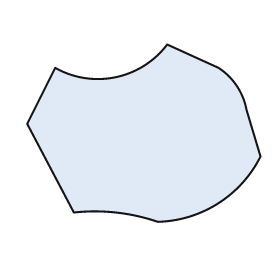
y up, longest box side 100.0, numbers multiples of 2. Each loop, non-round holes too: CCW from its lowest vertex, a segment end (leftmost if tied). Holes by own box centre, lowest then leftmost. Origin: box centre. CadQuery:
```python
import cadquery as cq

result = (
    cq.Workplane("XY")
    .moveTo(6.0, -38.0)
    .threePointArc((32.0, -30.0), (50.0, -10.0))
    .lineTo(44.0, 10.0)
    .threePointArc((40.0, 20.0), (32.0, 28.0))
    .lineTo(10.0, 38.0)
    .threePointArc((-12.0, 24.0), (-38.0, 28.0))
    .lineTo(-50.0, 4.0)
    .lineTo(-30.0, -34.0)
    .threePointArc((-12.0, -34.0), (6.0, -38.0))
    .close()
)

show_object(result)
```